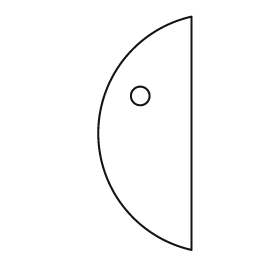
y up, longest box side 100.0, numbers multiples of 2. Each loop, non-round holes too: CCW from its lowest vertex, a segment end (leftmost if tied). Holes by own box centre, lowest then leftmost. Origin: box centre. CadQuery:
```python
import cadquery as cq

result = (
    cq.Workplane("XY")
    .moveTo(20.0, -50.0)
    .lineTo(20.0, 50.0)
    .threePointArc((-20.0, 0.0), (20.0, -50.0))
    .close()
    .moveTo(-2.0, 16.0)
    .circle(4.0)
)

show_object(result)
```